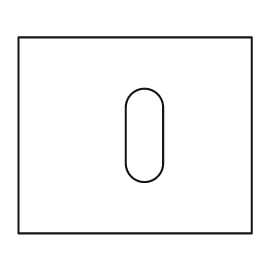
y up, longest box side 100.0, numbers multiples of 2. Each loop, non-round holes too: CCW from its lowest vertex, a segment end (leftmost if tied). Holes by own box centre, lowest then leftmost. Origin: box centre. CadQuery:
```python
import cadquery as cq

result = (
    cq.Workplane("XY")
    .moveTo(-50.0, -42.0)
    .lineTo(50.0, -42.0)
    .lineTo(50.0, 42.0)
    .lineTo(-50.0, 42.0)
    .close()
    .moveTo(-4.0, -12.0)
    .threePointArc((4.0, -20.0), (12.0, -12.0))
    .lineTo(12.0, 12.0)
    .threePointArc((4.0, 20.0), (-4.0, 12.0))
    .close()
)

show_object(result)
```